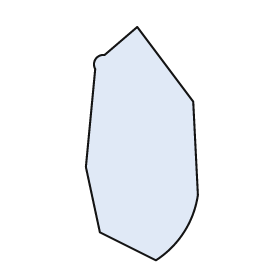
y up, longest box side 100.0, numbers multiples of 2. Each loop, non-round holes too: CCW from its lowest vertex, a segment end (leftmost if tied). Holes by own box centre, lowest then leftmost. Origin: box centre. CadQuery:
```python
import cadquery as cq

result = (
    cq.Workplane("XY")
    .moveTo(6.0, -50.0)
    .threePointArc((18.0, -38.0), (24.0, -22.0))
    .lineTo(22.0, 18.0)
    .lineTo(-2.0, 50.0)
    .lineTo(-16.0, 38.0)
    .threePointArc((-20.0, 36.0), (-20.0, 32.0))
    .lineTo(-24.0, -10.0)
    .lineTo(-18.0, -38.0)
    .close()
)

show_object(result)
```